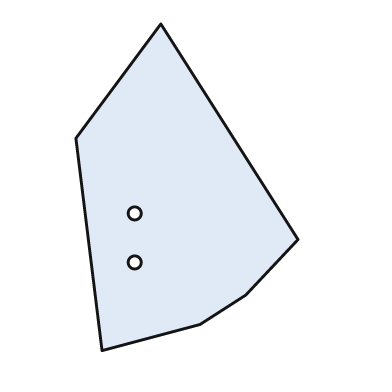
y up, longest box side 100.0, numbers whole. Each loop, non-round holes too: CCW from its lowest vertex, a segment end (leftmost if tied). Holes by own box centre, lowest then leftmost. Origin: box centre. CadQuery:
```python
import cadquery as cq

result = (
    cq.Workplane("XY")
    .moveTo(-26.0, -50.0)
    .lineTo(4.0, -42.0)
    .lineTo(18.0, -33.0)
    .lineTo(34.0, -16.0)
    .lineTo(-8.0, 50.0)
    .lineTo(-34.0, 15.0)
    .close()
    .moveTo(-16.0, -23.0)
    .circle(2.0)
    .moveTo(-16.0, -8.0)
    .circle(2.0)
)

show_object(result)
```